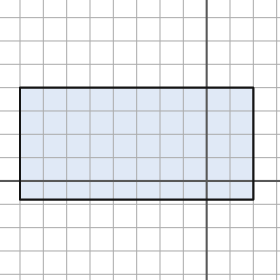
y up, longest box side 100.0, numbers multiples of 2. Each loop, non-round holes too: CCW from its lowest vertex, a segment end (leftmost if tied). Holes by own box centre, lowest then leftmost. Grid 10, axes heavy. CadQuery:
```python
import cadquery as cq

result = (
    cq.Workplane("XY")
    .moveTo(-80.0, -8.0)
    .lineTo(20.0, -8.0)
    .lineTo(20.0, 40.0)
    .lineTo(-80.0, 40.0)
    .close()
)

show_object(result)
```